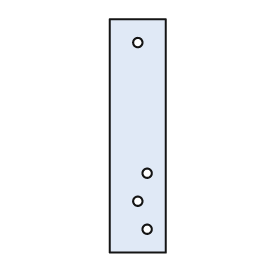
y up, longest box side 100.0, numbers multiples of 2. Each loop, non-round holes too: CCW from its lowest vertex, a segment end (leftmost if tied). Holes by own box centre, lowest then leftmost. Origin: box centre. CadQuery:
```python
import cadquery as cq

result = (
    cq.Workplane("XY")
    .moveTo(-12.0, -50.0)
    .lineTo(12.0, -50.0)
    .lineTo(12.0, 50.0)
    .lineTo(-12.0, 50.0)
    .close()
    .moveTo(4.0, -40.0)
    .circle(2.0)
    .moveTo(0.0, -28.0)
    .circle(2.0)
    .moveTo(4.0, -16.0)
    .circle(2.0)
    .moveTo(0.0, 40.0)
    .circle(2.0)
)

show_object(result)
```